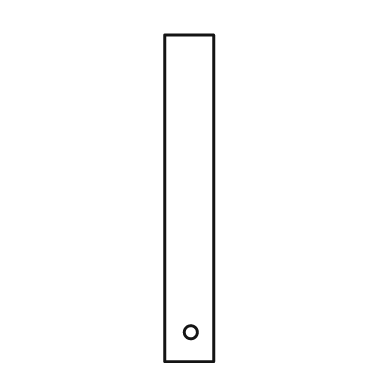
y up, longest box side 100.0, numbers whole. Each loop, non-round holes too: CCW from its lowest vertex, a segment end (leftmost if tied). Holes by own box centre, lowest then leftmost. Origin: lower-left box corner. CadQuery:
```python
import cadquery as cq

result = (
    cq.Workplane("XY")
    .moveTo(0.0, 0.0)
    .lineTo(15.0, 0.0)
    .lineTo(15.0, 100.0)
    .lineTo(0.0, 100.0)
    .close()
    .moveTo(8.0, 9.0)
    .circle(2.0)
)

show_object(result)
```